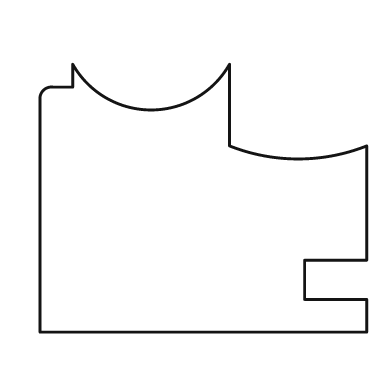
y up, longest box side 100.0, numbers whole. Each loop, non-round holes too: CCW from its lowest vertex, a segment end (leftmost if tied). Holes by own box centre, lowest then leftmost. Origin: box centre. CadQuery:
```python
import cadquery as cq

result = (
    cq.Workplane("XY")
    .moveTo(-50.0, -41.0)
    .lineTo(50.0, -41.0)
    .lineTo(50.0, -31.0)
    .lineTo(31.0, -31.0)
    .lineTo(31.0, -19.0)
    .lineTo(50.0, -19.0)
    .lineTo(50.0, 16.0)
    .threePointArc((29.0, 12.0), (8.0, 16.0))
    .lineTo(8.0, 41.0)
    .threePointArc((-16.0, 27.0), (-40.0, 41.0))
    .lineTo(-40.0, 34.0)
    .lineTo(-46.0, 34.0)
    .threePointArc((-49.0, 33.0), (-50.0, 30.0))
    .close()
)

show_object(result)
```